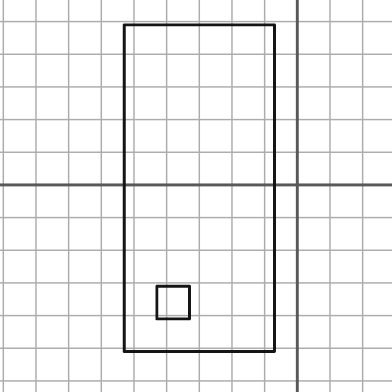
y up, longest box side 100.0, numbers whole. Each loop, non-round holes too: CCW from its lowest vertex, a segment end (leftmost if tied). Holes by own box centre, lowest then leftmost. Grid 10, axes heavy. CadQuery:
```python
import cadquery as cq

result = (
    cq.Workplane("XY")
    .moveTo(-53.0, -51.0)
    .lineTo(-7.0, -51.0)
    .lineTo(-7.0, 49.0)
    .lineTo(-53.0, 49.0)
    .close()
    .moveTo(-43.0, -41.0)
    .lineTo(-33.0, -41.0)
    .lineTo(-33.0, -31.0)
    .lineTo(-43.0, -31.0)
    .close()
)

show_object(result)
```